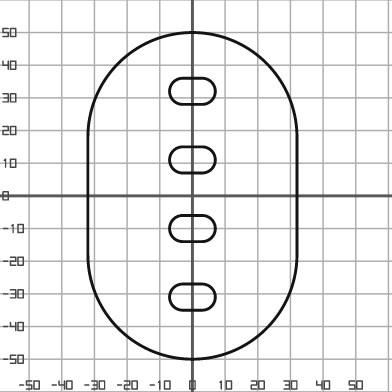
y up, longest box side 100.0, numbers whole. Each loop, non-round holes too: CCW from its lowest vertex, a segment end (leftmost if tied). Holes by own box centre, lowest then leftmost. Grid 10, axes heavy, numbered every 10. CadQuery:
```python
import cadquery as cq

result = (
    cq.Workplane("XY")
    .moveTo(-32.0, -18.0)
    .threePointArc((0.0, -50.0), (32.0, -18.0))
    .lineTo(32.0, 18.0)
    .threePointArc((0.0, 50.0), (-32.0, 18.0))
    .close()
    .moveTo(-3.0, -35.0)
    .lineTo(3.0, -35.0)
    .threePointArc((7.0, -31.0), (3.0, -27.0))
    .lineTo(-3.0, -27.0)
    .threePointArc((-7.0, -31.0), (-3.0, -35.0))
    .close()
    .moveTo(-3.0, -14.0)
    .lineTo(3.0, -14.0)
    .threePointArc((7.0, -10.0), (3.0, -6.0))
    .lineTo(-3.0, -6.0)
    .threePointArc((-7.0, -10.0), (-3.0, -14.0))
    .close()
    .moveTo(-3.0, 7.0)
    .lineTo(3.0, 7.0)
    .threePointArc((7.0, 11.0), (3.0, 15.0))
    .lineTo(-3.0, 15.0)
    .threePointArc((-7.0, 11.0), (-3.0, 7.0))
    .close()
    .moveTo(-3.0, 28.0)
    .lineTo(3.0, 28.0)
    .threePointArc((7.0, 32.0), (3.0, 36.0))
    .lineTo(-3.0, 36.0)
    .threePointArc((-7.0, 32.0), (-3.0, 28.0))
    .close()
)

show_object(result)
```